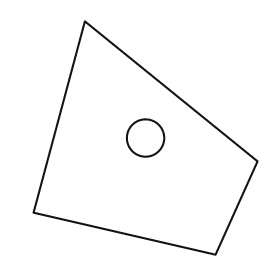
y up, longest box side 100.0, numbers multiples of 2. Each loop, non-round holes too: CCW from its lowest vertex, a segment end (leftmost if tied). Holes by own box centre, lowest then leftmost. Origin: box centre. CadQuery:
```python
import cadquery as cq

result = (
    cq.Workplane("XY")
    .moveTo(30.0, -50.0)
    .lineTo(48.0, -10.0)
    .lineTo(-26.0, 50.0)
    .lineTo(-48.0, -32.0)
    .close()
    .moveTo(0.0, 0.0)
    .circle(8.0)
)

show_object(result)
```